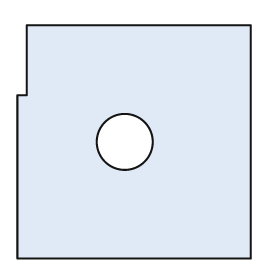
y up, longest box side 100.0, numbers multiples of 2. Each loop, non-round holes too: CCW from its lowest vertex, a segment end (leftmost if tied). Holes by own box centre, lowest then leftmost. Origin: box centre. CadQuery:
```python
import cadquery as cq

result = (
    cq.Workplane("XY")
    .moveTo(-50.0, -50.0)
    .lineTo(50.0, -50.0)
    .lineTo(50.0, 50.0)
    .lineTo(-46.0, 50.0)
    .lineTo(-46.0, 20.0)
    .lineTo(-50.0, 20.0)
    .close()
    .moveTo(-4.0, 0.0)
    .circle(12.0)
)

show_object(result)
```